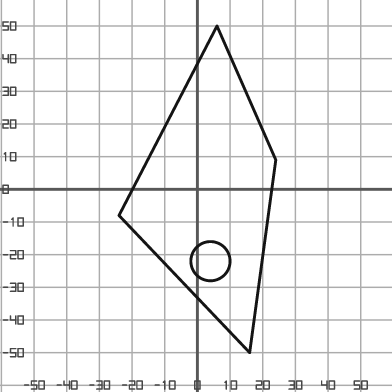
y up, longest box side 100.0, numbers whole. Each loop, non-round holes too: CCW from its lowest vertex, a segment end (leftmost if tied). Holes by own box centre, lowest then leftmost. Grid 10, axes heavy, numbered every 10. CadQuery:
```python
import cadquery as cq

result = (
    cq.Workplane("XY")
    .moveTo(16.0, -50.0)
    .lineTo(24.0, 9.0)
    .lineTo(6.0, 50.0)
    .lineTo(-24.0, -8.0)
    .close()
    .moveTo(4.0, -22.0)
    .circle(6.0)
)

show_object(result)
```